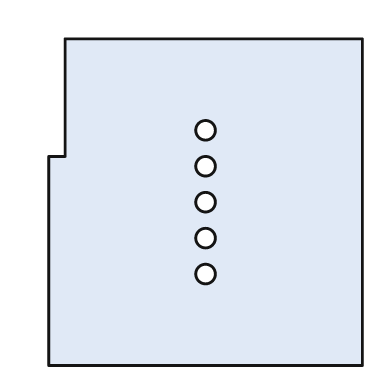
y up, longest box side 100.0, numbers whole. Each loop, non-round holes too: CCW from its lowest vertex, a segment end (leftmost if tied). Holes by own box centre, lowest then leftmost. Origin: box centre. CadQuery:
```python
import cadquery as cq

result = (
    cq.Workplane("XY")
    .moveTo(-48.0, -50.0)
    .lineTo(48.0, -50.0)
    .lineTo(48.0, 50.0)
    .lineTo(-43.0, 50.0)
    .lineTo(-43.0, 14.0)
    .lineTo(-48.0, 14.0)
    .close()
    .moveTo(0.0, -22.0)
    .circle(3.0)
    .moveTo(0.0, -11.0)
    .circle(3.0)
    .moveTo(0.0, 0.0)
    .circle(3.0)
    .moveTo(0.0, 11.0)
    .circle(3.0)
    .moveTo(0.0, 22.0)
    .circle(3.0)
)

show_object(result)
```